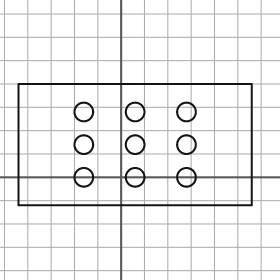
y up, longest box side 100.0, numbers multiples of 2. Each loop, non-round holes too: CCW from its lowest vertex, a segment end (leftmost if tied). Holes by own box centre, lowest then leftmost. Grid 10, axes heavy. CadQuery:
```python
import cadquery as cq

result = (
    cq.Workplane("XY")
    .moveTo(-44.0, -12.0)
    .lineTo(56.0, -12.0)
    .lineTo(56.0, 40.0)
    .lineTo(-44.0, 40.0)
    .close()
    .moveTo(-16.0, 0.0)
    .circle(4.0)
    .moveTo(6.0, 0.0)
    .circle(4.0)
    .moveTo(28.0, 0.0)
    .circle(4.0)
    .moveTo(-16.0, 14.0)
    .circle(4.0)
    .moveTo(6.0, 14.0)
    .circle(4.0)
    .moveTo(28.0, 14.0)
    .circle(4.0)
    .moveTo(-16.0, 28.0)
    .circle(4.0)
    .moveTo(6.0, 28.0)
    .circle(4.0)
    .moveTo(28.0, 28.0)
    .circle(4.0)
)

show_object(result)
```